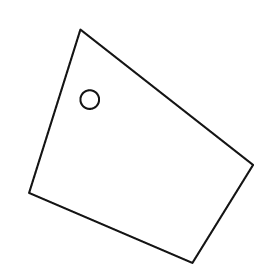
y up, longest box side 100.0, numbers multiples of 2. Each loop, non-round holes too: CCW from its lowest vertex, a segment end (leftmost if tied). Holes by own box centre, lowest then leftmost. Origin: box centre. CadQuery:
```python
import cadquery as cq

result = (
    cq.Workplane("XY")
    .moveTo(22.0, -50.0)
    .lineTo(48.0, -8.0)
    .lineTo(-26.0, 50.0)
    .lineTo(-48.0, -20.0)
    .close()
    .moveTo(-22.0, 20.0)
    .circle(4.0)
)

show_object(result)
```